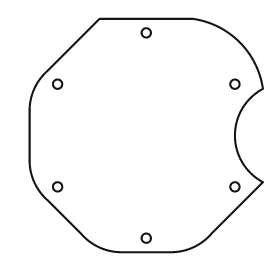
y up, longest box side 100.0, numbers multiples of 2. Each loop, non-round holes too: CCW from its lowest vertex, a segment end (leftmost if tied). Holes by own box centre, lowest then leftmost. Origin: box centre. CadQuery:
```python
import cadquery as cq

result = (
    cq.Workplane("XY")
    .moveTo(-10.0, -50.0)
    .lineTo(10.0, -50.0)
    .threePointArc((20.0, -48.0), (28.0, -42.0))
    .lineTo(50.0, -20.0)
    .threePointArc((38.0, 0.0), (50.0, 20.0))
    .threePointArc((40.0, 40.0), (20.0, 50.0))
    .lineTo(-20.0, 50.0)
    .lineTo(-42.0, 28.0)
    .threePointArc((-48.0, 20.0), (-50.0, 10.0))
    .lineTo(-50.0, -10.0)
    .threePointArc((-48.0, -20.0), (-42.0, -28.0))
    .lineTo(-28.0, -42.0)
    .threePointArc((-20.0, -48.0), (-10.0, -50.0))
    .close()
    .moveTo(0.0, -44.0)
    .circle(2.0)
    .moveTo(-38.0, -22.0)
    .circle(2.0)
    .moveTo(38.0, -22.0)
    .circle(2.0)
    .moveTo(-38.0, 22.0)
    .circle(2.0)
    .moveTo(38.0, 22.0)
    .circle(2.0)
    .moveTo(0.0, 44.0)
    .circle(2.0)
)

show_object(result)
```